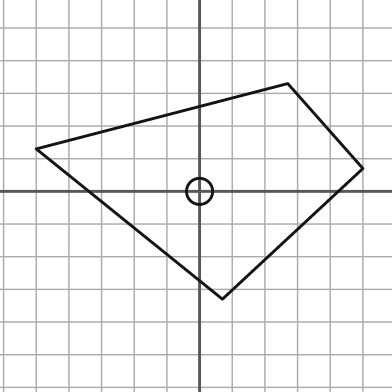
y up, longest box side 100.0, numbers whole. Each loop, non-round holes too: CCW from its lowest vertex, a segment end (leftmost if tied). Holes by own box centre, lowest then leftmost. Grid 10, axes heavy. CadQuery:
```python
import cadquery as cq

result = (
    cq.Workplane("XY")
    .moveTo(7.0, -33.0)
    .lineTo(50.0, 7.0)
    .lineTo(27.0, 33.0)
    .lineTo(-50.0, 13.0)
    .close()
    .moveTo(0.0, 0.0)
    .circle(4.0)
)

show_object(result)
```